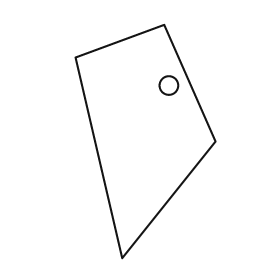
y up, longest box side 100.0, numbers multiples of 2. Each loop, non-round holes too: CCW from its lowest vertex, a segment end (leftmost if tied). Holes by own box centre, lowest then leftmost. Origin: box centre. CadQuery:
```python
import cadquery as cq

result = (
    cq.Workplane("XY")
    .moveTo(-10.0, -50.0)
    .lineTo(30.0, 0.0)
    .lineTo(8.0, 50.0)
    .lineTo(-30.0, 36.0)
    .close()
    .moveTo(10.0, 24.0)
    .circle(4.0)
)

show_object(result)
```